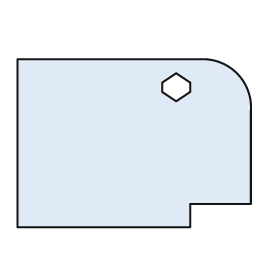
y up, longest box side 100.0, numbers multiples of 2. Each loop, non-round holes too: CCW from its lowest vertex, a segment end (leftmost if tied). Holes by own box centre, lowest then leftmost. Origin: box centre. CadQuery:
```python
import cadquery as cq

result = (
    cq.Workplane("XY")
    .moveTo(-50.0, -36.0)
    .lineTo(24.0, -36.0)
    .lineTo(24.0, -26.0)
    .lineTo(50.0, -26.0)
    .lineTo(50.0, 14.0)
    .threePointArc((44.0, 30.0), (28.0, 36.0))
    .lineTo(-50.0, 36.0)
    .close()
    .moveTo(18.0, 18.0)
    .lineTo(24.0, 22.0)
    .lineTo(24.0, 26.0)
    .lineTo(18.0, 30.0)
    .lineTo(12.0, 26.0)
    .lineTo(12.0, 22.0)
    .close()
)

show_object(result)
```